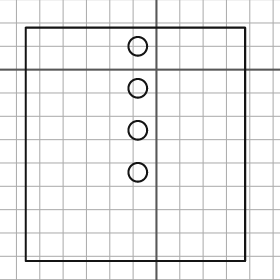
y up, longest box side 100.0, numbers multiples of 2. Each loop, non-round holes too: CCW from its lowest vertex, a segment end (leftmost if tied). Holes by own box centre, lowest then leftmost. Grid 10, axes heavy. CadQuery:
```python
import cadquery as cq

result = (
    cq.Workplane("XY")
    .moveTo(-56.0, -82.0)
    .lineTo(38.0, -82.0)
    .lineTo(38.0, 18.0)
    .lineTo(-56.0, 18.0)
    .close()
    .moveTo(-8.0, -44.0)
    .circle(4.0)
    .moveTo(-8.0, -26.0)
    .circle(4.0)
    .moveTo(-8.0, -8.0)
    .circle(4.0)
    .moveTo(-8.0, 10.0)
    .circle(4.0)
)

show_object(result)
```